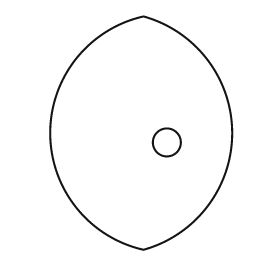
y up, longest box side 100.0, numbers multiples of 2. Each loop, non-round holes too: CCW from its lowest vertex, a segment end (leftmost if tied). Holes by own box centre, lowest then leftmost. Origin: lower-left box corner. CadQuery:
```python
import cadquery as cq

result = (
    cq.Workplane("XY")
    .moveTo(40.0, 0.0)
    .threePointArc((78.0, 50.0), (40.0, 100.0))
    .threePointArc((0.0, 50.0), (40.0, 0.0))
    .close()
    .moveTo(50.0, 46.0)
    .circle(6.0)
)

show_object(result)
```